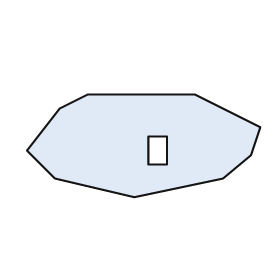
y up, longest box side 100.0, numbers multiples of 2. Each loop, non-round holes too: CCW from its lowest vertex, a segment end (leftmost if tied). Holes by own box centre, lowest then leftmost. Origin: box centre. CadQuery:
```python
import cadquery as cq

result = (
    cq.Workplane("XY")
    .moveTo(-4.0, -22.0)
    .lineTo(34.0, -14.0)
    .lineTo(46.0, -4.0)
    .lineTo(50.0, 8.0)
    .lineTo(22.0, 22.0)
    .lineTo(-24.0, 22.0)
    .lineTo(-36.0, 16.0)
    .lineTo(-50.0, -2.0)
    .lineTo(-38.0, -14.0)
    .close()
    .moveTo(2.0, -8.0)
    .lineTo(10.0, -8.0)
    .lineTo(10.0, 4.0)
    .lineTo(2.0, 4.0)
    .close()
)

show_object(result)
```